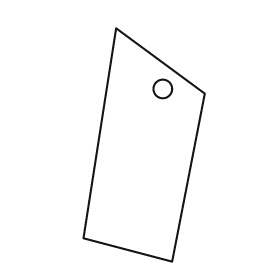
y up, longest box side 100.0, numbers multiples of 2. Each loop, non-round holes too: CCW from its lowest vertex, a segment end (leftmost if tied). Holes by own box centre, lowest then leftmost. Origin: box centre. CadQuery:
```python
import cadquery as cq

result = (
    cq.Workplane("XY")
    .moveTo(12.0, -50.0)
    .lineTo(26.0, 22.0)
    .lineTo(-12.0, 50.0)
    .lineTo(-26.0, -40.0)
    .close()
    .moveTo(8.0, 24.0)
    .circle(4.0)
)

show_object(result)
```